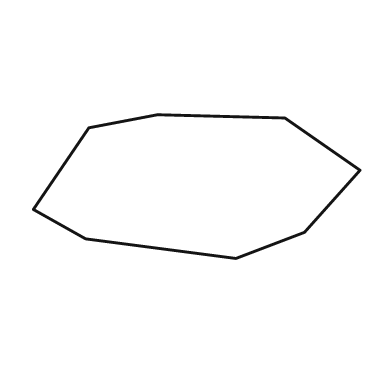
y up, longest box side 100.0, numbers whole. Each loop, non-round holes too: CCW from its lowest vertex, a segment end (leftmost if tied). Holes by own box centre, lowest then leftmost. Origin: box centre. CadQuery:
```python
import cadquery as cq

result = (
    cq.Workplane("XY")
    .moveTo(12.0, -22.0)
    .lineTo(33.0, -14.0)
    .lineTo(50.0, 5.0)
    .lineTo(27.0, 21.0)
    .lineTo(-12.0, 22.0)
    .lineTo(-33.0, 18.0)
    .lineTo(-50.0, -7.0)
    .lineTo(-34.0, -16.0)
    .close()
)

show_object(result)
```